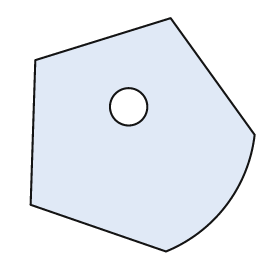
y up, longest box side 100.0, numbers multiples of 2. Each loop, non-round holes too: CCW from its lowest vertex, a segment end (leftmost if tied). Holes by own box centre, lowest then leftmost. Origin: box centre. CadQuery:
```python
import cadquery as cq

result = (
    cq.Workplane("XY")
    .moveTo(10.0, -50.0)
    .threePointArc((36.0, -30.0), (48.0, 0.0))
    .lineTo(12.0, 50.0)
    .lineTo(-46.0, 32.0)
    .lineTo(-48.0, -30.0)
    .close()
    .moveTo(-6.0, 12.0)
    .circle(8.0)
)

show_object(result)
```